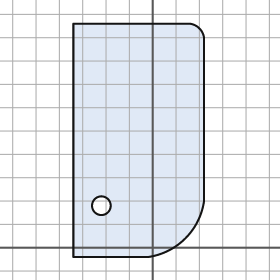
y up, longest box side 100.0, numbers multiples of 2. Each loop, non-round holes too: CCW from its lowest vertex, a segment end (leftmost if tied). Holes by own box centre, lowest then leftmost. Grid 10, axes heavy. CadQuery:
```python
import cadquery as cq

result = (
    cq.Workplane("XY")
    .moveTo(-34.0, -4.0)
    .lineTo(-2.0, -4.0)
    .threePointArc((14.0, 4.0), (22.0, 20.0))
    .lineTo(22.0, 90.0)
    .threePointArc((20.0, 94.0), (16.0, 96.0))
    .lineTo(-34.0, 96.0)
    .close()
    .moveTo(-22.0, 18.0)
    .circle(4.0)
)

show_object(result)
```